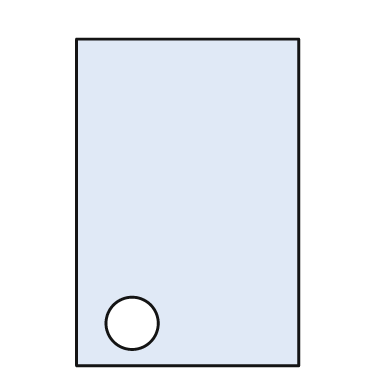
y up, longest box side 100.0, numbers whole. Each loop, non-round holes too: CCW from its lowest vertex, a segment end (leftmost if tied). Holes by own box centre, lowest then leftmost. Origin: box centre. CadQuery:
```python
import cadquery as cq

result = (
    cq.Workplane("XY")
    .moveTo(-34.0, -50.0)
    .lineTo(34.0, -50.0)
    .lineTo(34.0, 50.0)
    .lineTo(-34.0, 50.0)
    .close()
    .moveTo(-17.0, -37.0)
    .circle(8.0)
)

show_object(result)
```